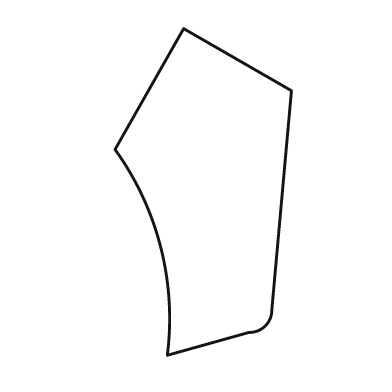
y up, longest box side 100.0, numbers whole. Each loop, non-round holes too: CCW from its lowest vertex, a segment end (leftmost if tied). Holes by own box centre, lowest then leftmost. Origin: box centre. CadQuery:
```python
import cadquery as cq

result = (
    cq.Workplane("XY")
    .moveTo(-11.0, -50.0)
    .lineTo(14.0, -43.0)
    .threePointArc((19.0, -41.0), (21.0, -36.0))
    .lineTo(27.0, 31.0)
    .lineTo(-6.0, 50.0)
    .lineTo(-27.0, 13.0)
    .threePointArc((-13.0, -17.0), (-11.0, -50.0))
    .close()
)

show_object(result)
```